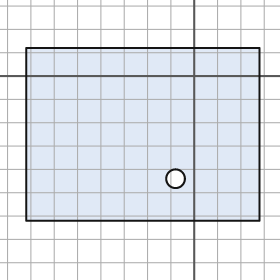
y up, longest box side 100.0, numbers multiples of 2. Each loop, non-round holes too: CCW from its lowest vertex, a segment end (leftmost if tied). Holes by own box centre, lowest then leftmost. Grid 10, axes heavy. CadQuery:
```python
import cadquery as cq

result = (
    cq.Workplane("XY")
    .moveTo(-72.0, -62.0)
    .lineTo(28.0, -62.0)
    .lineTo(28.0, 12.0)
    .lineTo(-72.0, 12.0)
    .close()
    .moveTo(-8.0, -44.0)
    .circle(4.0)
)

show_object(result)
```